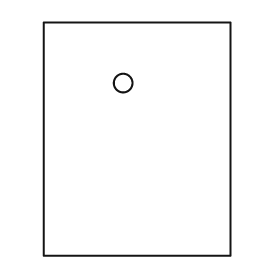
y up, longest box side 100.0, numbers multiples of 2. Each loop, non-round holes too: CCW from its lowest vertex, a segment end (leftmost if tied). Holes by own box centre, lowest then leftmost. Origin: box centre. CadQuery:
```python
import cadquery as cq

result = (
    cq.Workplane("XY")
    .moveTo(-40.0, -50.0)
    .lineTo(40.0, -50.0)
    .lineTo(40.0, 50.0)
    .lineTo(-40.0, 50.0)
    .close()
    .moveTo(-6.0, 24.0)
    .circle(4.0)
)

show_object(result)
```